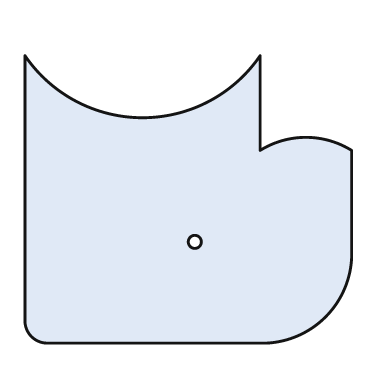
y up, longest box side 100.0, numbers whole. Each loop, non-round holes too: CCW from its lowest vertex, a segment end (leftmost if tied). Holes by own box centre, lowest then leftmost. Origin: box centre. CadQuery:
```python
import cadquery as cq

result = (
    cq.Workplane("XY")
    .moveTo(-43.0, -44.0)
    .lineTo(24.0, -44.0)
    .threePointArc((42.0, -36.0), (50.0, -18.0))
    .lineTo(50.0, 15.0)
    .threePointArc((36.0, 19.0), (22.0, 15.0))
    .lineTo(22.0, 44.0)
    .threePointArc((-14.0, 25.0), (-50.0, 44.0))
    .lineTo(-50.0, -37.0)
    .threePointArc((-48.0, -42.0), (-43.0, -44.0))
    .close()
    .moveTo(2.0, -13.0)
    .circle(2.0)
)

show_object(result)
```